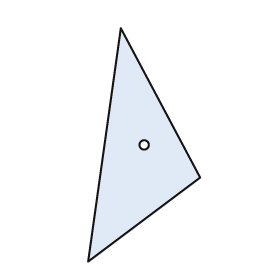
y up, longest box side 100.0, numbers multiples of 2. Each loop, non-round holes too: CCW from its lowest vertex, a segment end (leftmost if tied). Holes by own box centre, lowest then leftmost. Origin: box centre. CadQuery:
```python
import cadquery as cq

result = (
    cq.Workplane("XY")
    .moveTo(-24.0, -50.0)
    .lineTo(24.0, -14.0)
    .lineTo(-10.0, 50.0)
    .close()
    .moveTo(0.0, 0.0)
    .circle(2.0)
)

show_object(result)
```